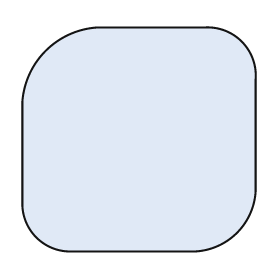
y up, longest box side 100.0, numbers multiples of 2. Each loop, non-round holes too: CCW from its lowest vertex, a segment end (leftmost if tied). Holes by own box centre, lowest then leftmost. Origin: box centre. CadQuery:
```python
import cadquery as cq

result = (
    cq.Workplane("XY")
    .moveTo(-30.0, -48.0)
    .lineTo(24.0, -48.0)
    .threePointArc((42.0, -40.0), (50.0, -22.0))
    .lineTo(50.0, 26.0)
    .threePointArc((44.0, 42.0), (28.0, 48.0))
    .lineTo(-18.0, 48.0)
    .threePointArc((-40.0, 38.0), (-50.0, 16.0))
    .lineTo(-50.0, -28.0)
    .threePointArc((-44.0, -42.0), (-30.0, -48.0))
    .close()
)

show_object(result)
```